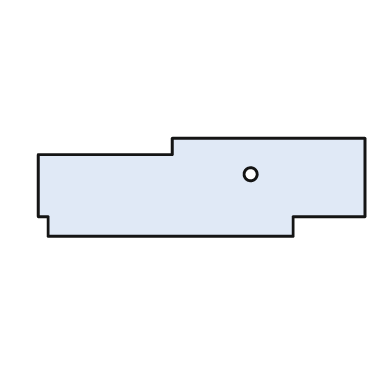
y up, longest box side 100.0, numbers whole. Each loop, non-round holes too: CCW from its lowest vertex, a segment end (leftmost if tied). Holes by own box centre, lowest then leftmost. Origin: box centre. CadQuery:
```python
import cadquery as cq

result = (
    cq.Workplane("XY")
    .moveTo(-47.0, -15.0)
    .lineTo(28.0, -15.0)
    .lineTo(28.0, -9.0)
    .lineTo(50.0, -9.0)
    .lineTo(50.0, 15.0)
    .lineTo(-9.0, 15.0)
    .lineTo(-9.0, 10.0)
    .lineTo(-50.0, 10.0)
    .lineTo(-50.0, -9.0)
    .lineTo(-47.0, -9.0)
    .close()
    .moveTo(15.0, 4.0)
    .circle(2.0)
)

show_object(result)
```